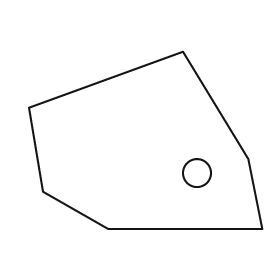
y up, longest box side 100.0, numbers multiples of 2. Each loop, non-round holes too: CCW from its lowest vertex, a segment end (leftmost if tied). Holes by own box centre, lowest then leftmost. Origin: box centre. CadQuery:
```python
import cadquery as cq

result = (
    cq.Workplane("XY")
    .moveTo(-16.0, -38.0)
    .lineTo(50.0, -38.0)
    .lineTo(44.0, -8.0)
    .lineTo(16.0, 38.0)
    .lineTo(-50.0, 14.0)
    .lineTo(-44.0, -22.0)
    .close()
    .moveTo(22.0, -14.0)
    .circle(6.0)
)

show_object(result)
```